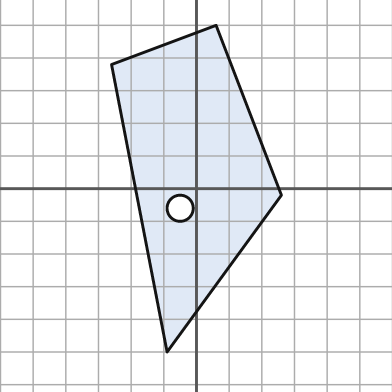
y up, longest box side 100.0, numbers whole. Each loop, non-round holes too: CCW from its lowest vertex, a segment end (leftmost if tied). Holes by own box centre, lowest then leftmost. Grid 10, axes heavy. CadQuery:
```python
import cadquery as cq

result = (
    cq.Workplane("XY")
    .moveTo(-9.0, -50.0)
    .lineTo(26.0, -2.0)
    .lineTo(6.0, 50.0)
    .lineTo(-26.0, 38.0)
    .close()
    .moveTo(-5.0, -6.0)
    .circle(4.0)
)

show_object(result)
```